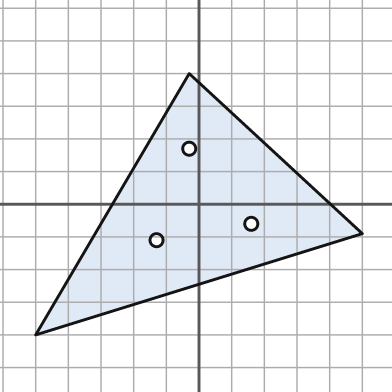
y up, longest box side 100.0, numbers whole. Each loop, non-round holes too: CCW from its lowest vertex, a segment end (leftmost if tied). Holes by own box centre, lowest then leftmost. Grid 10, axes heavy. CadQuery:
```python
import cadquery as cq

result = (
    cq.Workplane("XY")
    .moveTo(-50.0, -40.0)
    .lineTo(50.0, -9.0)
    .lineTo(-3.0, 40.0)
    .close()
    .moveTo(-13.0, -11.0)
    .circle(2.0)
    .moveTo(16.0, -6.0)
    .circle(2.0)
    .moveTo(-3.0, 17.0)
    .circle(2.0)
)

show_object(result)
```